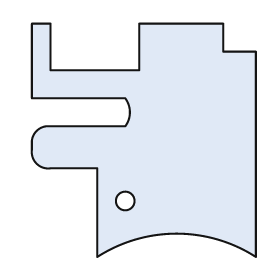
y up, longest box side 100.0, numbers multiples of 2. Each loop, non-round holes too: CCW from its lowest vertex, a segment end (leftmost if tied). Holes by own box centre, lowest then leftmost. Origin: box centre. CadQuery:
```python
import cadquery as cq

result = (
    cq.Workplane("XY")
    .moveTo(-20.0, -50.0)
    .threePointArc((14.0, -40.0), (48.0, -50.0))
    .lineTo(48.0, 38.0)
    .lineTo(34.0, 38.0)
    .lineTo(34.0, 50.0)
    .lineTo(-2.0, 50.0)
    .lineTo(-2.0, 30.0)
    .lineTo(-40.0, 30.0)
    .lineTo(-40.0, 50.0)
    .lineTo(-48.0, 50.0)
    .lineTo(-48.0, 18.0)
    .lineTo(-8.0, 18.0)
    .threePointArc((-6.0, 12.0), (-8.0, 6.0))
    .lineTo(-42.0, 6.0)
    .threePointArc((-46.0, 4.0), (-48.0, 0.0))
    .lineTo(-48.0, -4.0)
    .threePointArc((-46.0, -10.0), (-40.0, -12.0))
    .lineTo(-20.0, -12.0)
    .close()
    .moveTo(-8.0, -26.0)
    .circle(4.0)
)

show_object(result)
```